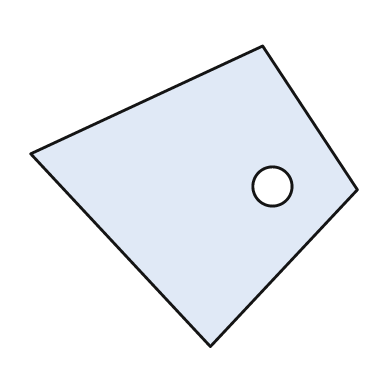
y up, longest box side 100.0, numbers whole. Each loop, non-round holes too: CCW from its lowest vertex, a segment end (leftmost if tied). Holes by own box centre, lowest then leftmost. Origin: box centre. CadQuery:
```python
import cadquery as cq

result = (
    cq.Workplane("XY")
    .moveTo(5.0, -46.0)
    .lineTo(50.0, 2.0)
    .lineTo(21.0, 46.0)
    .lineTo(-50.0, 13.0)
    .close()
    .moveTo(24.0, 3.0)
    .circle(6.0)
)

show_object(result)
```